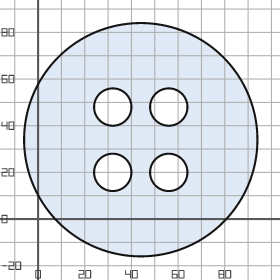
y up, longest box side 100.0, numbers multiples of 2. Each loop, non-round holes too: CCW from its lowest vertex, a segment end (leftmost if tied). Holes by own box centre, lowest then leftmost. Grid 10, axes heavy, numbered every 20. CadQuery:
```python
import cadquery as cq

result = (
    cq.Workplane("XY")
    .moveTo(44.0, 34.0)
    .circle(50.0)
    .moveTo(32.0, 20.0)
    .circle(8.0)
    .moveTo(56.0, 20.0)
    .circle(8.0)
    .moveTo(32.0, 48.0)
    .circle(8.0)
    .moveTo(56.0, 48.0)
    .circle(8.0)
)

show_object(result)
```